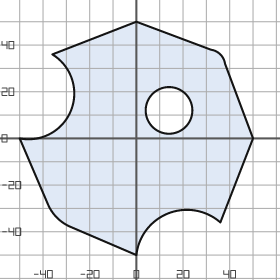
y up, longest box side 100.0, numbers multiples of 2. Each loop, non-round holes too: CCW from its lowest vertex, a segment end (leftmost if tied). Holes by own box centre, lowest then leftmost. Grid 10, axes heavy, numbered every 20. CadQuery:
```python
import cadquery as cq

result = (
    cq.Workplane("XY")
    .moveTo(0.0, -50.0)
    .threePointArc((14.0, -32.0), (36.0, -36.0))
    .lineTo(50.0, 0.0)
    .lineTo(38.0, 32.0)
    .threePointArc((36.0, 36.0), (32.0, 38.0))
    .lineTo(0.0, 50.0)
    .lineTo(-36.0, 36.0)
    .threePointArc((-28.0, 12.0), (-50.0, 0.0))
    .lineTo(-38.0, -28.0)
    .threePointArc((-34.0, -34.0), (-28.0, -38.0))
    .close()
    .moveTo(14.0, 12.0)
    .circle(10.0)
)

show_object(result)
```